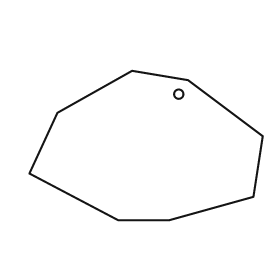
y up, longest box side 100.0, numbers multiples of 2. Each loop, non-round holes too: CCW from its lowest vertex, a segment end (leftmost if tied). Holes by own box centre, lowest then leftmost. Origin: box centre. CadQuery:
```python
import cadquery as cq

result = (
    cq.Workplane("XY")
    .moveTo(-12.0, -32.0)
    .lineTo(10.0, -32.0)
    .lineTo(46.0, -22.0)
    .lineTo(50.0, 4.0)
    .lineTo(18.0, 28.0)
    .lineTo(-6.0, 32.0)
    .lineTo(-38.0, 14.0)
    .lineTo(-50.0, -12.0)
    .close()
    .moveTo(14.0, 22.0)
    .circle(2.0)
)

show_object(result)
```